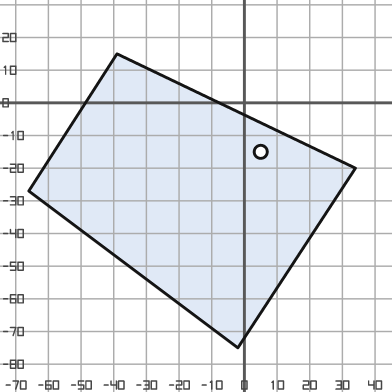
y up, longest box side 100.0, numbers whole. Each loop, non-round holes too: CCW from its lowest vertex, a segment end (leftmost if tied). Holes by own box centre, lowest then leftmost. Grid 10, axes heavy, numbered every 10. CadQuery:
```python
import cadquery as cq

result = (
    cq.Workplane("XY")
    .moveTo(-2.0, -75.0)
    .lineTo(34.0, -20.0)
    .lineTo(-39.0, 15.0)
    .lineTo(-66.0, -27.0)
    .close()
    .moveTo(5.0, -15.0)
    .circle(2.0)
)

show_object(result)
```